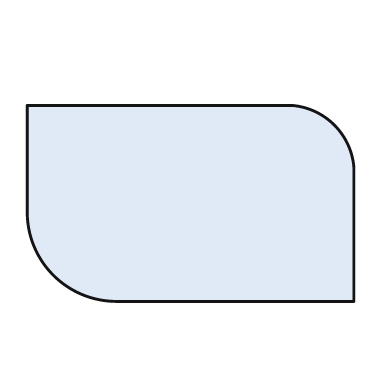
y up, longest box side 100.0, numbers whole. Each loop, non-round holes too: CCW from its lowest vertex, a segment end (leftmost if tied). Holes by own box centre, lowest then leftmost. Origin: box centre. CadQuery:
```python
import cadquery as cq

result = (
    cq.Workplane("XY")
    .moveTo(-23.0, -30.0)
    .lineTo(50.0, -30.0)
    .lineTo(50.0, 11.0)
    .threePointArc((44.0, 24.0), (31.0, 30.0))
    .lineTo(-50.0, 30.0)
    .lineTo(-50.0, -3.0)
    .threePointArc((-42.0, -22.0), (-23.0, -30.0))
    .close()
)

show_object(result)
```